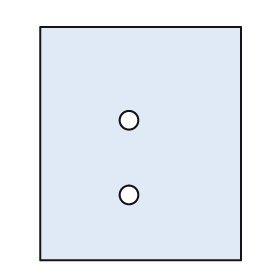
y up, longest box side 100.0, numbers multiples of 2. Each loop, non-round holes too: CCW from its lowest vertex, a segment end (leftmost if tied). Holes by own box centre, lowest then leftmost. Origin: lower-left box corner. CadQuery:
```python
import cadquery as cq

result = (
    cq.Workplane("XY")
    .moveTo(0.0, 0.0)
    .lineTo(86.0, 0.0)
    .lineTo(86.0, 100.0)
    .lineTo(0.0, 100.0)
    .close()
    .moveTo(38.0, 28.0)
    .circle(4.0)
    .moveTo(38.0, 60.0)
    .circle(4.0)
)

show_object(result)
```